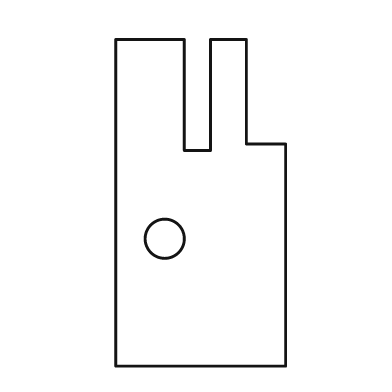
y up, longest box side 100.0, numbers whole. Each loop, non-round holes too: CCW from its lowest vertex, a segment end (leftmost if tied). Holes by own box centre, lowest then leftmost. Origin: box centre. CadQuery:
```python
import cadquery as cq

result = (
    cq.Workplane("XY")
    .moveTo(-26.0, -50.0)
    .lineTo(26.0, -50.0)
    .lineTo(26.0, 18.0)
    .lineTo(14.0, 18.0)
    .lineTo(14.0, 50.0)
    .lineTo(3.0, 50.0)
    .lineTo(3.0, 16.0)
    .lineTo(-5.0, 16.0)
    .lineTo(-5.0, 50.0)
    .lineTo(-26.0, 50.0)
    .close()
    .moveTo(-11.0, -11.0)
    .circle(6.0)
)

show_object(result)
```